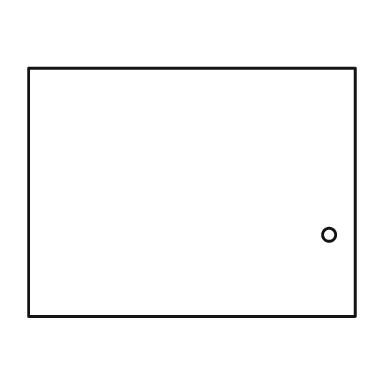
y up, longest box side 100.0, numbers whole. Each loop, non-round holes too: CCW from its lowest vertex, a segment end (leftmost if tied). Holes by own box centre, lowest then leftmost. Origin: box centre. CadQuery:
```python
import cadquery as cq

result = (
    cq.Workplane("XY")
    .moveTo(-50.0, -38.0)
    .lineTo(50.0, -38.0)
    .lineTo(50.0, 38.0)
    .lineTo(-50.0, 38.0)
    .close()
    .moveTo(42.0, -13.0)
    .circle(2.0)
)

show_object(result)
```